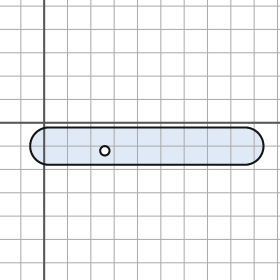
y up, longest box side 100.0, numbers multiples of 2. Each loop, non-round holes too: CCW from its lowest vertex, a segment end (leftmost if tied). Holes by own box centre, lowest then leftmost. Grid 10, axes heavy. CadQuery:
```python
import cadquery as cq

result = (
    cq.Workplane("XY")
    .moveTo(2.0, -18.0)
    .lineTo(86.0, -18.0)
    .threePointArc((94.0, -10.0), (86.0, -2.0))
    .lineTo(2.0, -2.0)
    .threePointArc((-6.0, -10.0), (2.0, -18.0))
    .close()
    .moveTo(26.0, -12.0)
    .circle(2.0)
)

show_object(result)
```